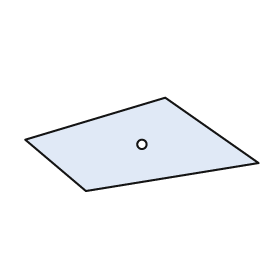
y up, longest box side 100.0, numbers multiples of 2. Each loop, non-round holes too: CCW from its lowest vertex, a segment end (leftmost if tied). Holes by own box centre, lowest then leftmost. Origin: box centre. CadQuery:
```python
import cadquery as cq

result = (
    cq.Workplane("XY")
    .moveTo(-24.0, -20.0)
    .lineTo(50.0, -8.0)
    .lineTo(10.0, 20.0)
    .lineTo(-50.0, 2.0)
    .close()
    .moveTo(0.0, 0.0)
    .circle(2.0)
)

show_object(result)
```